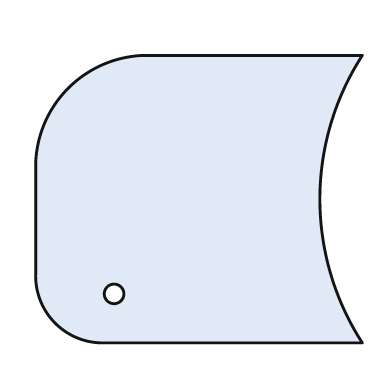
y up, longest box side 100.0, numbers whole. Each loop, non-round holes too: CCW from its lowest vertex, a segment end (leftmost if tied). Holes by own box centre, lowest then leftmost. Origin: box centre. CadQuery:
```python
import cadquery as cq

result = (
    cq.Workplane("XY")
    .moveTo(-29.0, -44.0)
    .lineTo(50.0, -44.0)
    .threePointArc((37.0, 0.0), (50.0, 44.0))
    .lineTo(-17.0, 44.0)
    .threePointArc((-40.0, 34.0), (-50.0, 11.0))
    .lineTo(-50.0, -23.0)
    .threePointArc((-44.0, -38.0), (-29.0, -44.0))
    .close()
    .moveTo(-26.0, -29.0)
    .circle(3.0)
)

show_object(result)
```